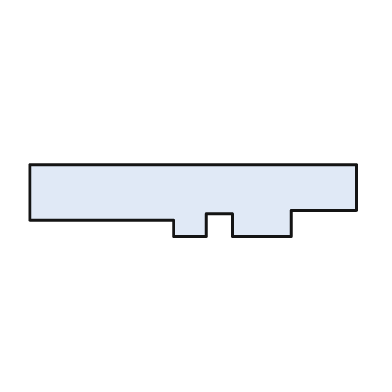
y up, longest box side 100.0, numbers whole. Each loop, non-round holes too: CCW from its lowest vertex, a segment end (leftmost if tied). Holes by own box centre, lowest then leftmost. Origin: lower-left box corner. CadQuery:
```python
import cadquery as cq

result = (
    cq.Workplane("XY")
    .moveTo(44.0, 0.0)
    .lineTo(54.0, 0.0)
    .lineTo(54.0, 7.0)
    .lineTo(62.0, 7.0)
    .lineTo(62.0, 0.0)
    .lineTo(80.0, 0.0)
    .lineTo(80.0, 8.0)
    .lineTo(100.0, 8.0)
    .lineTo(100.0, 22.0)
    .lineTo(0.0, 22.0)
    .lineTo(0.0, 5.0)
    .lineTo(44.0, 5.0)
    .close()
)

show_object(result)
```